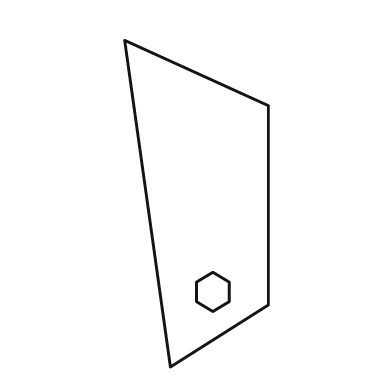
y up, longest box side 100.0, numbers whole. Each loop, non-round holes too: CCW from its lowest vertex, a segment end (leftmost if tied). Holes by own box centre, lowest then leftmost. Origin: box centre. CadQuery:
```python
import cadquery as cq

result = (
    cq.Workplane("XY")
    .moveTo(-8.0, -50.0)
    .lineTo(22.0, -31.0)
    .lineTo(22.0, 30.0)
    .lineTo(-22.0, 50.0)
    .close()
    .moveTo(5.0, -33.0)
    .lineTo(10.0, -30.0)
    .lineTo(10.0, -24.0)
    .lineTo(5.0, -21.0)
    .lineTo(0.0, -24.0)
    .lineTo(0.0, -30.0)
    .close()
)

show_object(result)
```